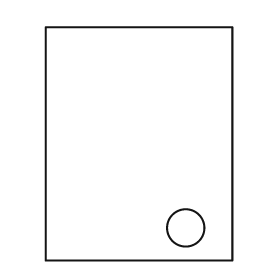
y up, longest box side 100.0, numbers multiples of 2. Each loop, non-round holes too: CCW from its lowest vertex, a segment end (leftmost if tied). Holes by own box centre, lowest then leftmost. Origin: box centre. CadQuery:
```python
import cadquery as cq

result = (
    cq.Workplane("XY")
    .moveTo(-40.0, -50.0)
    .lineTo(40.0, -50.0)
    .lineTo(40.0, 50.0)
    .lineTo(-40.0, 50.0)
    .close()
    .moveTo(20.0, -36.0)
    .circle(8.0)
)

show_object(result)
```